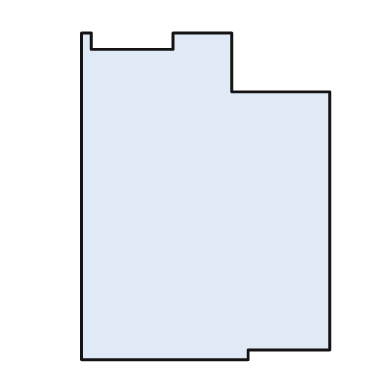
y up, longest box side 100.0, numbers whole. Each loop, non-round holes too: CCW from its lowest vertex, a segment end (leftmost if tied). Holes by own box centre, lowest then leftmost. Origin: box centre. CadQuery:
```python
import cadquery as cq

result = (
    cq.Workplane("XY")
    .moveTo(-38.0, -50.0)
    .lineTo(13.0, -50.0)
    .lineTo(13.0, -47.0)
    .lineTo(38.0, -47.0)
    .lineTo(38.0, 32.0)
    .lineTo(8.0, 32.0)
    .lineTo(8.0, 50.0)
    .lineTo(-10.0, 50.0)
    .lineTo(-10.0, 45.0)
    .lineTo(-35.0, 45.0)
    .lineTo(-35.0, 50.0)
    .lineTo(-38.0, 50.0)
    .close()
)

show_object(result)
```